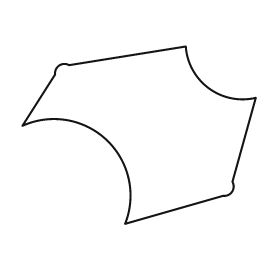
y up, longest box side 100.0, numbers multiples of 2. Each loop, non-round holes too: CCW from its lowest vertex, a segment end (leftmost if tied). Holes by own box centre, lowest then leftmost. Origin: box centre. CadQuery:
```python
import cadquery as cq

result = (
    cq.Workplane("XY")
    .moveTo(-6.0, -38.0)
    .lineTo(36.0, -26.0)
    .threePointArc((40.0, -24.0), (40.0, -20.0))
    .lineTo(50.0, 16.0)
    .threePointArc((30.0, 20.0), (20.0, 38.0))
    .lineTo(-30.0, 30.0)
    .threePointArc((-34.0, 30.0), (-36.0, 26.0))
    .lineTo(-50.0, 4.0)
    .threePointArc((-14.0, -2.0), (-6.0, -38.0))
    .close()
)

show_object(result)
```